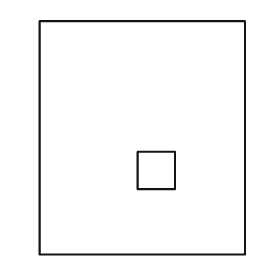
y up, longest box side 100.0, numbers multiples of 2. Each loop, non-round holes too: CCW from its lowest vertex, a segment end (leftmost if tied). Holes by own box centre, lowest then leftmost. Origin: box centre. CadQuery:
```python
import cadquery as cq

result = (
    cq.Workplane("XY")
    .moveTo(-44.0, -50.0)
    .lineTo(44.0, -50.0)
    .lineTo(44.0, 50.0)
    .lineTo(-44.0, 50.0)
    .close()
    .moveTo(-2.0, -22.0)
    .lineTo(14.0, -22.0)
    .lineTo(14.0, -6.0)
    .lineTo(-2.0, -6.0)
    .close()
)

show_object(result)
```